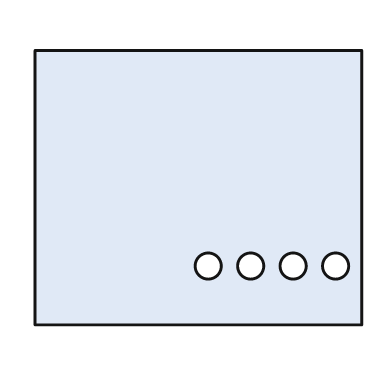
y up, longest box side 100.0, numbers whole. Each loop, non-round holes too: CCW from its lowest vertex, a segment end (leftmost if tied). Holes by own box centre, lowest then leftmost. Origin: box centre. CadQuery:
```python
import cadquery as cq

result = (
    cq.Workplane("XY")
    .moveTo(-50.0, -42.0)
    .lineTo(50.0, -42.0)
    .lineTo(50.0, 42.0)
    .lineTo(-50.0, 42.0)
    .close()
    .moveTo(3.0, -24.0)
    .circle(4.0)
    .moveTo(16.0, -24.0)
    .circle(4.0)
    .moveTo(29.0, -24.0)
    .circle(4.0)
    .moveTo(42.0, -24.0)
    .circle(4.0)
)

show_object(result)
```